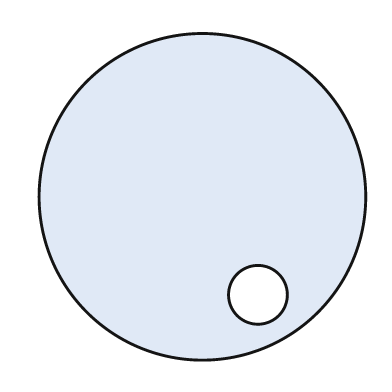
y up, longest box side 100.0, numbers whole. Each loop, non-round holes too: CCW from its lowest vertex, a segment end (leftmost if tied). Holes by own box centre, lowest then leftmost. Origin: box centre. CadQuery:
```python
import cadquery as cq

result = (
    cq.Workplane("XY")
    .moveTo(0.0, 0.0)
    .circle(50.0)
    .moveTo(17.0, -30.0)
    .circle(9.0)
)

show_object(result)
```